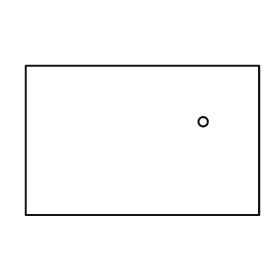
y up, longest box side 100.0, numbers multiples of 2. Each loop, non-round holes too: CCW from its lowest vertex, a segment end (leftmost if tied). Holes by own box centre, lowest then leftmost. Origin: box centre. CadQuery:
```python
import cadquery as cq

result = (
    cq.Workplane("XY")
    .moveTo(-50.0, -32.0)
    .lineTo(50.0, -32.0)
    .lineTo(50.0, 32.0)
    .lineTo(-50.0, 32.0)
    .close()
    .moveTo(26.0, 8.0)
    .circle(2.0)
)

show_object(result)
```